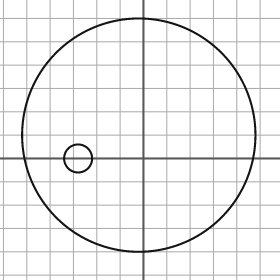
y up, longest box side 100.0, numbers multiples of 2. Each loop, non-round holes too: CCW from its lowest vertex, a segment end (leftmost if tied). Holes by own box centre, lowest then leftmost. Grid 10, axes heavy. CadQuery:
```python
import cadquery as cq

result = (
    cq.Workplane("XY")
    .moveTo(-2.0, 10.0)
    .circle(50.0)
    .moveTo(-28.0, 0.0)
    .circle(6.0)
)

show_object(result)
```